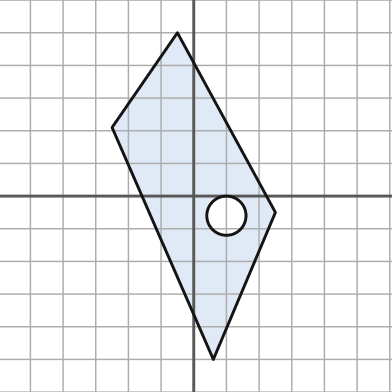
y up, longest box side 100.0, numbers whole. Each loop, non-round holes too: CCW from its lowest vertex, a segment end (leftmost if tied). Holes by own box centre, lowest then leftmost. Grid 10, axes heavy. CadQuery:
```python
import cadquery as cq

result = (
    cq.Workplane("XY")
    .moveTo(6.0, -50.0)
    .lineTo(25.0, -5.0)
    .lineTo(-5.0, 50.0)
    .lineTo(-25.0, 21.0)
    .close()
    .moveTo(10.0, -6.0)
    .circle(6.0)
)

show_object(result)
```